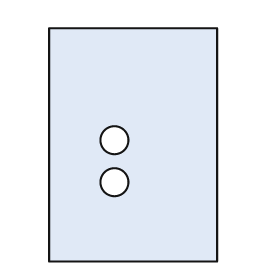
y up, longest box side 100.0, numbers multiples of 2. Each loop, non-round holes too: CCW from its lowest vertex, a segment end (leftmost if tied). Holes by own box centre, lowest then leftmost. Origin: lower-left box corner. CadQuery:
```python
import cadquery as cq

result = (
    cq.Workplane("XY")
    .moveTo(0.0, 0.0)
    .lineTo(72.0, 0.0)
    .lineTo(72.0, 100.0)
    .lineTo(0.0, 100.0)
    .close()
    .moveTo(28.0, 34.0)
    .circle(6.0)
    .moveTo(28.0, 52.0)
    .circle(6.0)
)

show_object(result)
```